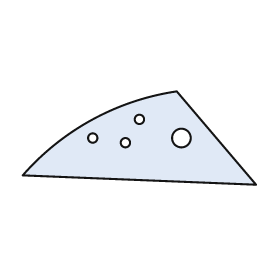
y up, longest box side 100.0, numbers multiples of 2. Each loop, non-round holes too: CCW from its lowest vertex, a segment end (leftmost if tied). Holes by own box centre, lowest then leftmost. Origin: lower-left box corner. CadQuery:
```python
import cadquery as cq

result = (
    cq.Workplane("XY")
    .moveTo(100.0, 0.0)
    .lineTo(66.0, 40.0)
    .threePointArc((30.0, 28.0), (0.0, 4.0))
    .close()
    .moveTo(44.0, 18.0)
    .circle(2.0)
    .moveTo(30.0, 20.0)
    .circle(2.0)
    .moveTo(68.0, 20.0)
    .circle(4.0)
    .moveTo(50.0, 28.0)
    .circle(2.0)
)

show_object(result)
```